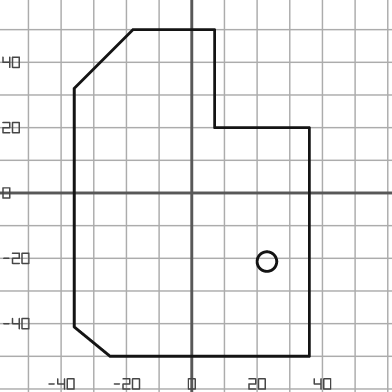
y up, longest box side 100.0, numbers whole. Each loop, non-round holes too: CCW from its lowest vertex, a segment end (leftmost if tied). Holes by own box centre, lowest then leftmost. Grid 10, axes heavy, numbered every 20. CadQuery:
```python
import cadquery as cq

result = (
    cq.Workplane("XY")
    .moveTo(-25.0, -50.0)
    .lineTo(36.0, -50.0)
    .lineTo(36.0, 20.0)
    .lineTo(7.0, 20.0)
    .lineTo(7.0, 50.0)
    .lineTo(-18.0, 50.0)
    .lineTo(-36.0, 32.0)
    .lineTo(-36.0, -41.0)
    .close()
    .moveTo(23.0, -21.0)
    .circle(3.0)
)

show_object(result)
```